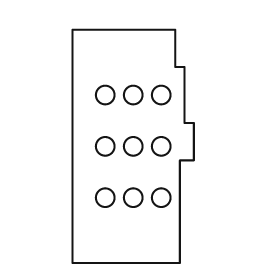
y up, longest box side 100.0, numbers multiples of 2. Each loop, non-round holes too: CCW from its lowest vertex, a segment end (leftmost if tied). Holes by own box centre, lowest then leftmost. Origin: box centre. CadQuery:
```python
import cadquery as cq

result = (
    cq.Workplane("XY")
    .moveTo(-26.0, -50.0)
    .lineTo(20.0, -50.0)
    .lineTo(20.0, -6.0)
    .lineTo(26.0, -6.0)
    .lineTo(26.0, 10.0)
    .lineTo(22.0, 10.0)
    .lineTo(22.0, 34.0)
    .lineTo(18.0, 34.0)
    .lineTo(18.0, 50.0)
    .lineTo(-26.0, 50.0)
    .close()
    .moveTo(-12.0, -22.0)
    .circle(4.0)
    .moveTo(0.0, -22.0)
    .circle(4.0)
    .moveTo(12.0, -22.0)
    .circle(4.0)
    .moveTo(-12.0, 0.0)
    .circle(4.0)
    .moveTo(0.0, 0.0)
    .circle(4.0)
    .moveTo(12.0, 0.0)
    .circle(4.0)
    .moveTo(-12.0, 22.0)
    .circle(4.0)
    .moveTo(0.0, 22.0)
    .circle(4.0)
    .moveTo(12.0, 22.0)
    .circle(4.0)
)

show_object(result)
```